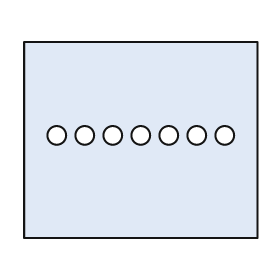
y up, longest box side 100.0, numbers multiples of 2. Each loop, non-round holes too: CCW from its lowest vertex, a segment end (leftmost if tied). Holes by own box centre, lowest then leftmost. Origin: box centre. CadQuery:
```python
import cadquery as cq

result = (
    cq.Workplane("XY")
    .moveTo(-50.0, -42.0)
    .lineTo(50.0, -42.0)
    .lineTo(50.0, 42.0)
    .lineTo(-50.0, 42.0)
    .close()
    .moveTo(-36.0, 2.0)
    .circle(4.0)
    .moveTo(-24.0, 2.0)
    .circle(4.0)
    .moveTo(-12.0, 2.0)
    .circle(4.0)
    .moveTo(0.0, 2.0)
    .circle(4.0)
    .moveTo(12.0, 2.0)
    .circle(4.0)
    .moveTo(24.0, 2.0)
    .circle(4.0)
    .moveTo(36.0, 2.0)
    .circle(4.0)
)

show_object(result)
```